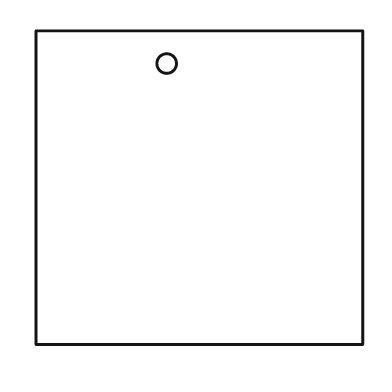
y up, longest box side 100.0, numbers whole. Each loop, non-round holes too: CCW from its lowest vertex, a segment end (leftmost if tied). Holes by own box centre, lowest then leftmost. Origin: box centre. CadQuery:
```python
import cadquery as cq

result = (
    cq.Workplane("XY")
    .moveTo(-50.0, -48.0)
    .lineTo(50.0, -48.0)
    .lineTo(50.0, 48.0)
    .lineTo(-50.0, 48.0)
    .close()
    .moveTo(-10.0, 38.0)
    .circle(3.0)
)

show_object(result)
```